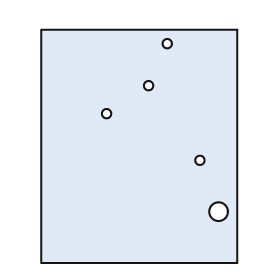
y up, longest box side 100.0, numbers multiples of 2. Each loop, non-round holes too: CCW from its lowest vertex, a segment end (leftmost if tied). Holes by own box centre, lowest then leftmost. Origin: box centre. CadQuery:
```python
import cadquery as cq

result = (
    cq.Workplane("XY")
    .moveTo(-42.0, -50.0)
    .lineTo(42.0, -50.0)
    .lineTo(42.0, 50.0)
    .lineTo(-42.0, 50.0)
    .close()
    .moveTo(34.0, -28.0)
    .circle(4.0)
    .moveTo(26.0, -6.0)
    .circle(2.0)
    .moveTo(-14.0, 14.0)
    .circle(2.0)
    .moveTo(4.0, 26.0)
    .circle(2.0)
    .moveTo(12.0, 44.0)
    .circle(2.0)
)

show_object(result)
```